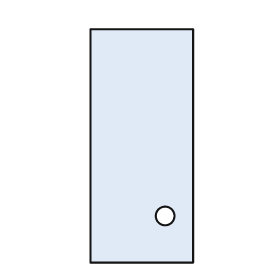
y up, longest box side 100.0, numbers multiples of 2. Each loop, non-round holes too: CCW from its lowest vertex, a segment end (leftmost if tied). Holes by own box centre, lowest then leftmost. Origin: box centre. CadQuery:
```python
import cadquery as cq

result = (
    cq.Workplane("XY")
    .moveTo(-22.0, -50.0)
    .lineTo(22.0, -50.0)
    .lineTo(22.0, 50.0)
    .lineTo(-22.0, 50.0)
    .close()
    .moveTo(10.0, -30.0)
    .circle(4.0)
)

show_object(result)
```